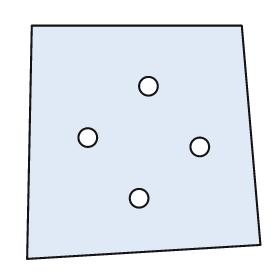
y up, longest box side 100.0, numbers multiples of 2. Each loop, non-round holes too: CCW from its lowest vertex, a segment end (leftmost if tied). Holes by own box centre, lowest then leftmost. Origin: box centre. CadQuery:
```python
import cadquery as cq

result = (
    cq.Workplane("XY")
    .moveTo(-50.0, -50.0)
    .lineTo(50.0, -44.0)
    .lineTo(42.0, 50.0)
    .lineTo(-48.0, 50.0)
    .close()
    .moveTo(-2.0, -24.0)
    .circle(4.0)
    .moveTo(24.0, -2.0)
    .circle(4.0)
    .moveTo(-24.0, 2.0)
    .circle(4.0)
    .moveTo(2.0, 24.0)
    .circle(4.0)
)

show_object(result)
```